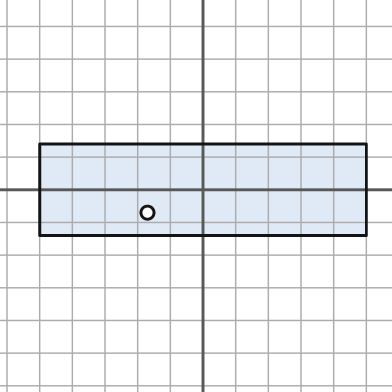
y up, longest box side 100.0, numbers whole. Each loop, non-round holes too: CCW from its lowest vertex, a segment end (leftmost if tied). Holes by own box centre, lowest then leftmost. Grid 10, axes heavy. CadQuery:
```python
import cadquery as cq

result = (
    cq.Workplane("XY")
    .moveTo(-50.0, -14.0)
    .lineTo(50.0, -14.0)
    .lineTo(50.0, 14.0)
    .lineTo(-50.0, 14.0)
    .close()
    .moveTo(-17.0, -7.0)
    .circle(2.0)
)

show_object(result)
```